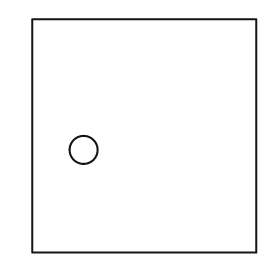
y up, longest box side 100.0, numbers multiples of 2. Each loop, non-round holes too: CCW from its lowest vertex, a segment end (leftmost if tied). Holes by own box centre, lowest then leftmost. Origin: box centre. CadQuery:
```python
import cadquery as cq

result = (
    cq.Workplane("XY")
    .moveTo(-48.0, -50.0)
    .lineTo(48.0, -50.0)
    .lineTo(48.0, 50.0)
    .lineTo(-48.0, 50.0)
    .close()
    .moveTo(-26.0, -6.0)
    .circle(6.0)
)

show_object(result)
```